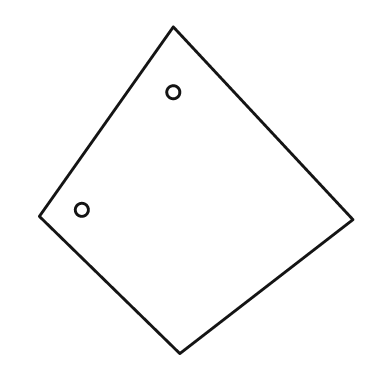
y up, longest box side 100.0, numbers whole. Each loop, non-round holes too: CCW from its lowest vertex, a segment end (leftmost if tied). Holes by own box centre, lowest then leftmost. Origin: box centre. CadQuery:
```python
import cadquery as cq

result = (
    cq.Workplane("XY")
    .moveTo(-5.0, -50.0)
    .lineTo(48.0, -9.0)
    .lineTo(-7.0, 50.0)
    .lineTo(-48.0, -8.0)
    .close()
    .moveTo(-35.0, -6.0)
    .circle(2.0)
    .moveTo(-7.0, 30.0)
    .circle(2.0)
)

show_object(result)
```